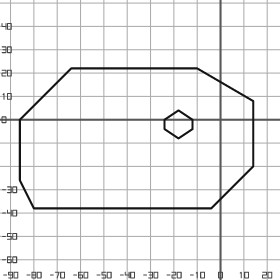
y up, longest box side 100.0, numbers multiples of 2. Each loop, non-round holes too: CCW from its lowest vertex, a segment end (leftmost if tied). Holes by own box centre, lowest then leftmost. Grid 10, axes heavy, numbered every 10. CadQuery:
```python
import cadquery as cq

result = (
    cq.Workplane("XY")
    .moveTo(-80.0, -38.0)
    .lineTo(-4.0, -38.0)
    .lineTo(14.0, -20.0)
    .lineTo(14.0, 8.0)
    .lineTo(-10.0, 22.0)
    .lineTo(-64.0, 22.0)
    .lineTo(-86.0, 0.0)
    .lineTo(-86.0, -26.0)
    .close()
    .moveTo(-18.0, -8.0)
    .lineTo(-12.0, -4.0)
    .lineTo(-12.0, 0.0)
    .lineTo(-18.0, 4.0)
    .lineTo(-24.0, 0.0)
    .lineTo(-24.0, -4.0)
    .close()
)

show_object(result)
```